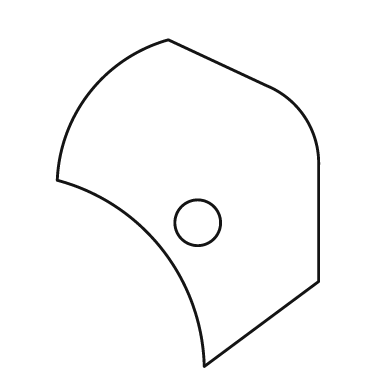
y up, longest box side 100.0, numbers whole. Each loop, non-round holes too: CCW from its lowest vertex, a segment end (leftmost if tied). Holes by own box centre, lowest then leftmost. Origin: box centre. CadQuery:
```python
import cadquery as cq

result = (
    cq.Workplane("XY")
    .moveTo(5.0, -50.0)
    .lineTo(40.0, -24.0)
    .lineTo(40.0, 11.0)
    .threePointArc((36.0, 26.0), (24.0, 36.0))
    .lineTo(-6.0, 50.0)
    .threePointArc((-30.0, 34.0), (-40.0, 7.0))
    .threePointArc((-8.0, -14.0), (5.0, -50.0))
    .close()
    .moveTo(3.0, -6.0)
    .circle(7.0)
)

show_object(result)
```